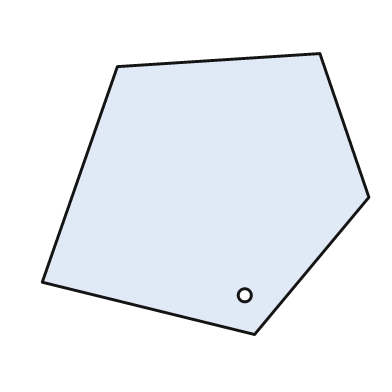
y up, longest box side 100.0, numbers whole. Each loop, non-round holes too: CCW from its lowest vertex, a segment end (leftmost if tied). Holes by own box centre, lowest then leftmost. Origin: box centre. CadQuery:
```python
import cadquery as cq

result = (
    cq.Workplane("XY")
    .moveTo(15.0, -43.0)
    .lineTo(50.0, -1.0)
    .lineTo(35.0, 43.0)
    .lineTo(-27.0, 39.0)
    .lineTo(-50.0, -27.0)
    .close()
    .moveTo(12.0, -31.0)
    .circle(2.0)
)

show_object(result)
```